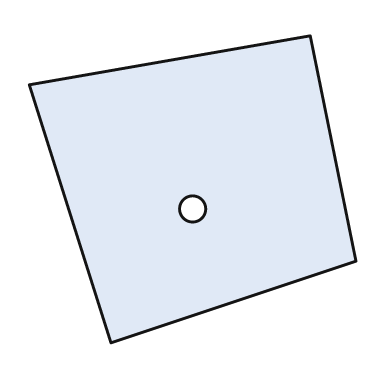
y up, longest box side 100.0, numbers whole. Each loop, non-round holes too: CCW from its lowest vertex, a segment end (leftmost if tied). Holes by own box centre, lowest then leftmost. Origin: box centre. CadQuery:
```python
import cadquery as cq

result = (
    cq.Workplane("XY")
    .moveTo(-25.0, -47.0)
    .lineTo(50.0, -22.0)
    .lineTo(36.0, 47.0)
    .lineTo(-50.0, 32.0)
    .close()
    .moveTo(0.0, -6.0)
    .circle(4.0)
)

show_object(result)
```